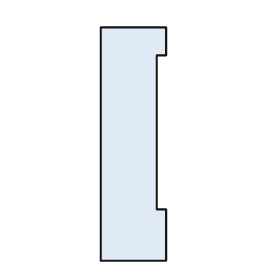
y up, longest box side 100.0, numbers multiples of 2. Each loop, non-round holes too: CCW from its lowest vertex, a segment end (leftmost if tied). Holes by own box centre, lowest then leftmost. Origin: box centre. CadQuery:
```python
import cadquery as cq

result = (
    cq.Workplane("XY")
    .moveTo(-14.0, -50.0)
    .lineTo(14.0, -50.0)
    .lineTo(14.0, -28.0)
    .lineTo(10.0, -28.0)
    .lineTo(10.0, 38.0)
    .lineTo(14.0, 38.0)
    .lineTo(14.0, 50.0)
    .lineTo(-14.0, 50.0)
    .close()
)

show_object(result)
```